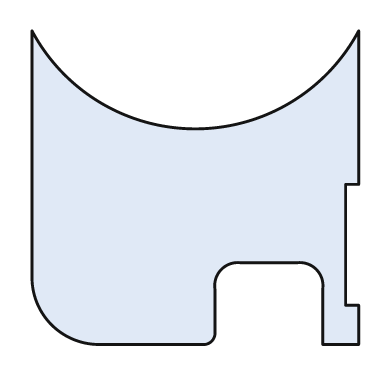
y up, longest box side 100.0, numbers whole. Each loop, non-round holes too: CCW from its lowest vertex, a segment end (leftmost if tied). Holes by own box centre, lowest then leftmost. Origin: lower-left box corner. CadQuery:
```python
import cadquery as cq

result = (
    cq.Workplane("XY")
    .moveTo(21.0, 0.0)
    .lineTo(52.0, 0.0)
    .threePointArc((55.0, 1.0), (56.0, 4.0))
    .lineTo(56.0, 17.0)
    .threePointArc((58.0, 23.0), (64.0, 25.0))
    .lineTo(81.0, 25.0)
    .threePointArc((87.0, 23.0), (89.0, 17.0))
    .lineTo(89.0, 0.0)
    .lineTo(100.0, 0.0)
    .lineTo(100.0, 12.0)
    .lineTo(96.0, 12.0)
    .lineTo(96.0, 49.0)
    .lineTo(100.0, 49.0)
    .lineTo(100.0, 96.0)
    .threePointArc((50.0, 66.0), (0.0, 96.0))
    .lineTo(0.0, 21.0)
    .threePointArc((6.0, 6.0), (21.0, 0.0))
    .close()
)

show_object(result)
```